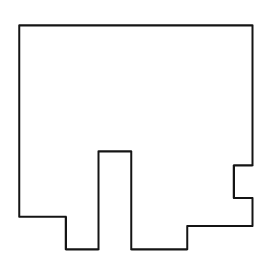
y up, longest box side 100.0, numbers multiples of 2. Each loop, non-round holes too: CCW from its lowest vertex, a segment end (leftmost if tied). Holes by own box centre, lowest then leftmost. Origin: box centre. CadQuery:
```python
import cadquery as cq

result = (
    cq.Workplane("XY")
    .moveTo(-30.0, -48.0)
    .lineTo(-16.0, -48.0)
    .lineTo(-16.0, -6.0)
    .lineTo(-2.0, -6.0)
    .lineTo(-2.0, -48.0)
    .lineTo(22.0, -48.0)
    .lineTo(22.0, -38.0)
    .lineTo(50.0, -38.0)
    .lineTo(50.0, -26.0)
    .lineTo(42.0, -26.0)
    .lineTo(42.0, -12.0)
    .lineTo(50.0, -12.0)
    .lineTo(50.0, 48.0)
    .lineTo(-50.0, 48.0)
    .lineTo(-50.0, -34.0)
    .lineTo(-30.0, -34.0)
    .close()
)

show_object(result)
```